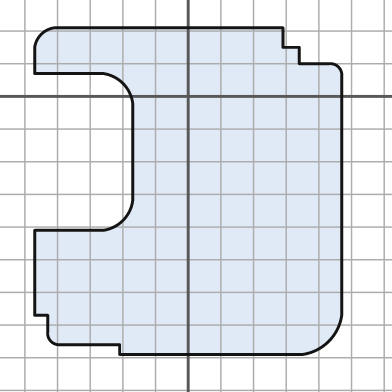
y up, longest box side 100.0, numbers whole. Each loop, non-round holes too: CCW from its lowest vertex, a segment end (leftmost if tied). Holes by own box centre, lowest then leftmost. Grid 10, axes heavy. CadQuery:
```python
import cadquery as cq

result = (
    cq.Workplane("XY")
    .moveTo(-21.0, -79.0)
    .lineTo(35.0, -79.0)
    .threePointArc((43.0, -75.0), (47.0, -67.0))
    .lineTo(47.0, 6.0)
    .threePointArc((46.0, 9.0), (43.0, 10.0))
    .lineTo(34.0, 10.0)
    .lineTo(34.0, 15.0)
    .lineTo(29.0, 15.0)
    .lineTo(29.0, 21.0)
    .lineTo(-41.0, 21.0)
    .threePointArc((-45.0, 19.0), (-47.0, 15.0))
    .lineTo(-47.0, 7.0)
    .lineTo(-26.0, 7.0)
    .threePointArc((-20.0, 4.0), (-17.0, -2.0))
    .lineTo(-17.0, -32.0)
    .threePointArc((-20.0, -38.0), (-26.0, -41.0))
    .lineTo(-47.0, -41.0)
    .lineTo(-47.0, -67.0)
    .lineTo(-43.0, -67.0)
    .lineTo(-43.0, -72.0)
    .threePointArc((-42.0, -75.0), (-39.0, -76.0))
    .lineTo(-21.0, -76.0)
    .close()
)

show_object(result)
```